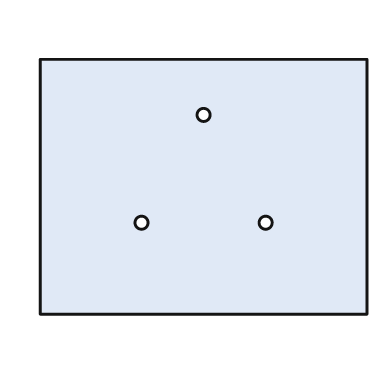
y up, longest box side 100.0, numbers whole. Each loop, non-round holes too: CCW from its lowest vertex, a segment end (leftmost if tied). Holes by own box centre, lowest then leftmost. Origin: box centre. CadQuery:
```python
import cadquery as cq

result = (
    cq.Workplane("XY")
    .moveTo(-50.0, -39.0)
    .lineTo(50.0, -39.0)
    .lineTo(50.0, 39.0)
    .lineTo(-50.0, 39.0)
    .close()
    .moveTo(-19.0, -11.0)
    .circle(2.0)
    .moveTo(19.0, -11.0)
    .circle(2.0)
    .moveTo(0.0, 22.0)
    .circle(2.0)
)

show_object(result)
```